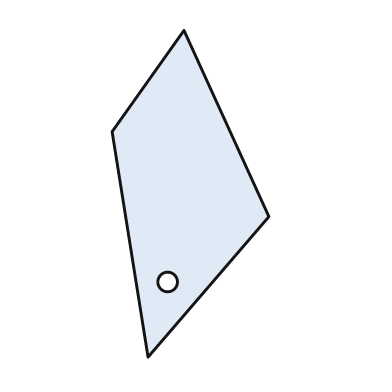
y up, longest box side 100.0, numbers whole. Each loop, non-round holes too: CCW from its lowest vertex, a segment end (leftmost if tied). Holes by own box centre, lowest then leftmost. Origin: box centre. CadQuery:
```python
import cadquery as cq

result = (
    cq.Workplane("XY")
    .moveTo(-13.0, -50.0)
    .lineTo(24.0, -7.0)
    .lineTo(-2.0, 50.0)
    .lineTo(-24.0, 19.0)
    .close()
    .moveTo(-7.0, -27.0)
    .circle(3.0)
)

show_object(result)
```